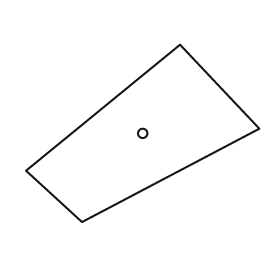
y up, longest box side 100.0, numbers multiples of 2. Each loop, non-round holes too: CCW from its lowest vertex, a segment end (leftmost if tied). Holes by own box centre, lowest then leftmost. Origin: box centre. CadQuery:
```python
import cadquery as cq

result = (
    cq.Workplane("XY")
    .moveTo(-26.0, -38.0)
    .lineTo(50.0, 2.0)
    .lineTo(16.0, 38.0)
    .lineTo(-50.0, -16.0)
    .close()
    .moveTo(0.0, 0.0)
    .circle(2.0)
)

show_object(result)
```